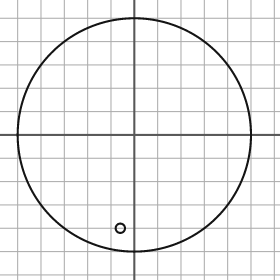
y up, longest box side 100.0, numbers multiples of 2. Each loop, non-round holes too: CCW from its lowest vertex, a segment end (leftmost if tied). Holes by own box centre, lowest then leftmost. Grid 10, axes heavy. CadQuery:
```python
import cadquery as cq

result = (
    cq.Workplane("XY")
    .moveTo(0.0, 0.0)
    .circle(50.0)
    .moveTo(-6.0, -40.0)
    .circle(2.0)
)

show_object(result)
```